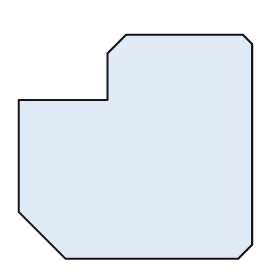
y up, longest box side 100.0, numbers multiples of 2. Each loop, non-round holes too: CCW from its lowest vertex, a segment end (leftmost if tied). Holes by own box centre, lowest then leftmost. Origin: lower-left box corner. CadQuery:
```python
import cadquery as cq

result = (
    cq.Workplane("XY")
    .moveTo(20.0, 0.0)
    .lineTo(94.0, 0.0)
    .lineTo(100.0, 6.0)
    .lineTo(100.0, 92.0)
    .lineTo(96.0, 96.0)
    .lineTo(46.0, 96.0)
    .lineTo(38.0, 88.0)
    .lineTo(38.0, 68.0)
    .lineTo(0.0, 68.0)
    .lineTo(0.0, 20.0)
    .close()
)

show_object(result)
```